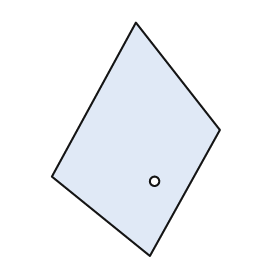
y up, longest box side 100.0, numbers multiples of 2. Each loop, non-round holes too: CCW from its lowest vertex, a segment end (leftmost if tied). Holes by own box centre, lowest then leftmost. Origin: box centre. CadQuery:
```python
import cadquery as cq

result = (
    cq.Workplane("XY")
    .moveTo(6.0, -50.0)
    .lineTo(36.0, 4.0)
    .lineTo(0.0, 50.0)
    .lineTo(-36.0, -16.0)
    .close()
    .moveTo(8.0, -18.0)
    .circle(2.0)
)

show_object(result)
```